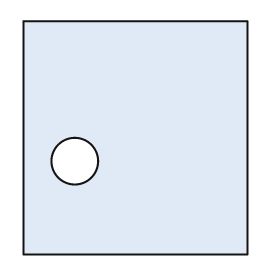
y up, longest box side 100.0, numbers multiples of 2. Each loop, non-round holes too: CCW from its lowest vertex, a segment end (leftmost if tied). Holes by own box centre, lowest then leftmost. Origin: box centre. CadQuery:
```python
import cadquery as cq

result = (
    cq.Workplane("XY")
    .moveTo(-48.0, -50.0)
    .lineTo(48.0, -50.0)
    .lineTo(48.0, 50.0)
    .lineTo(-48.0, 50.0)
    .close()
    .moveTo(-26.0, -10.0)
    .circle(10.0)
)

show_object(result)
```